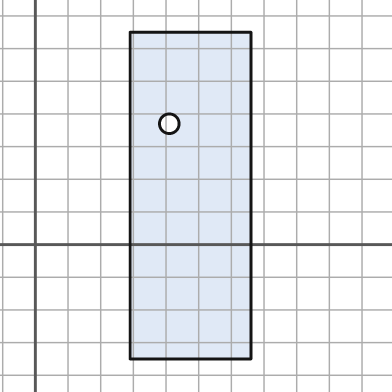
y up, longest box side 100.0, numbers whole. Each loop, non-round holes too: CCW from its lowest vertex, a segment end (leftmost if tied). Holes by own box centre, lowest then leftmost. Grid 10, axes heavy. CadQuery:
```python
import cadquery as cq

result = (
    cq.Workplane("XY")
    .moveTo(29.0, -35.0)
    .lineTo(66.0, -35.0)
    .lineTo(66.0, 65.0)
    .lineTo(29.0, 65.0)
    .close()
    .moveTo(41.0, 37.0)
    .circle(3.0)
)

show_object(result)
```